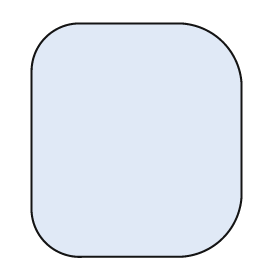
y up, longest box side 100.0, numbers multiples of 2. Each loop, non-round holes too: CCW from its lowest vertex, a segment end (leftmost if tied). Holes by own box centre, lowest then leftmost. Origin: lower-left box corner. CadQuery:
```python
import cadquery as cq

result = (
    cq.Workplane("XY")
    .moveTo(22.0, 0.0)
    .lineTo(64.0, 0.0)
    .threePointArc((82.0, 8.0), (90.0, 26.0))
    .lineTo(90.0, 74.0)
    .threePointArc((82.0, 92.0), (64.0, 100.0))
    .lineTo(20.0, 100.0)
    .threePointArc((6.0, 94.0), (0.0, 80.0))
    .lineTo(0.0, 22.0)
    .threePointArc((6.0, 6.0), (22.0, 0.0))
    .close()
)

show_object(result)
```